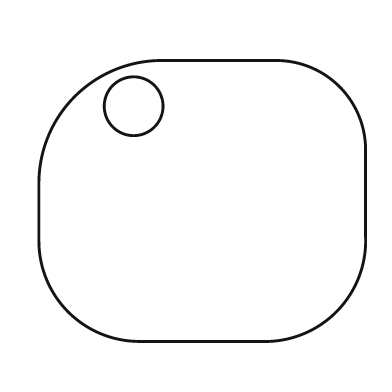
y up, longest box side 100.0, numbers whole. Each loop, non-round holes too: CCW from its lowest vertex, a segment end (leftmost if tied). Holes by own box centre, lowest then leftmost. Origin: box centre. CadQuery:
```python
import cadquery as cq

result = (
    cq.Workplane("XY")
    .moveTo(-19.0, -43.0)
    .lineTo(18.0, -43.0)
    .threePointArc((41.0, -34.0), (50.0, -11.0))
    .lineTo(50.0, 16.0)
    .threePointArc((42.0, 35.0), (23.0, 43.0))
    .lineTo(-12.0, 43.0)
    .threePointArc((-39.0, 32.0), (-50.0, 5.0))
    .lineTo(-50.0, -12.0)
    .threePointArc((-41.0, -34.0), (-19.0, -43.0))
    .close()
    .moveTo(-21.0, 29.0)
    .circle(9.0)
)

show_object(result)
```